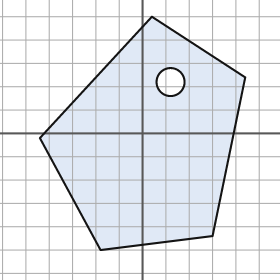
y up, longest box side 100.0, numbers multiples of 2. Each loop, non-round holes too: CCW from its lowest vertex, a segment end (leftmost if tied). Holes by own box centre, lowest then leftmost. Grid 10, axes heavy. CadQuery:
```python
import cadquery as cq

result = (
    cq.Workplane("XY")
    .moveTo(-18.0, -50.0)
    .lineTo(30.0, -44.0)
    .lineTo(44.0, 24.0)
    .lineTo(4.0, 50.0)
    .lineTo(-44.0, -2.0)
    .close()
    .moveTo(12.0, 22.0)
    .circle(6.0)
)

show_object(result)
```